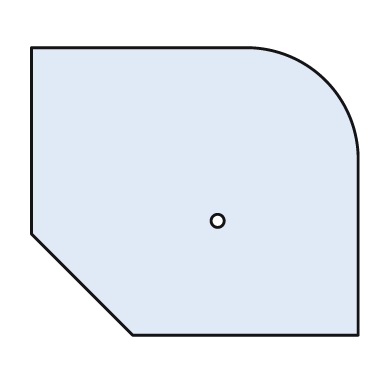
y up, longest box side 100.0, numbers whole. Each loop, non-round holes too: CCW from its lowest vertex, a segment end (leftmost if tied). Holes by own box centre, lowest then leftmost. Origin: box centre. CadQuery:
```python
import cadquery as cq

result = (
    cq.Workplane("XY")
    .moveTo(-19.0, -44.0)
    .lineTo(50.0, -44.0)
    .lineTo(50.0, 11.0)
    .threePointArc((40.0, 34.0), (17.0, 44.0))
    .lineTo(-50.0, 44.0)
    .lineTo(-50.0, -13.0)
    .close()
    .moveTo(7.0, -9.0)
    .circle(2.0)
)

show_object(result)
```